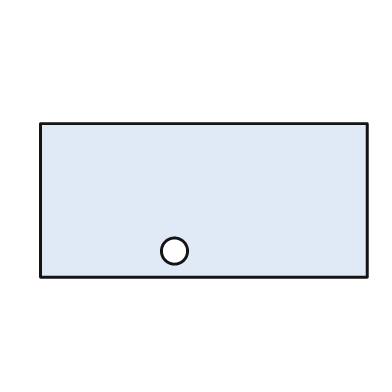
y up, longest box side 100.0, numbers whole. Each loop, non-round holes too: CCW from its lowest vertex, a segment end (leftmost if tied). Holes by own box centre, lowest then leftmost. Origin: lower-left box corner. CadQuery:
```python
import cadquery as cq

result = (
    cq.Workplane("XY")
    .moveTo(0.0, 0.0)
    .lineTo(100.0, 0.0)
    .lineTo(100.0, 47.0)
    .lineTo(0.0, 47.0)
    .close()
    .moveTo(41.0, 8.0)
    .circle(4.0)
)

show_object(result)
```